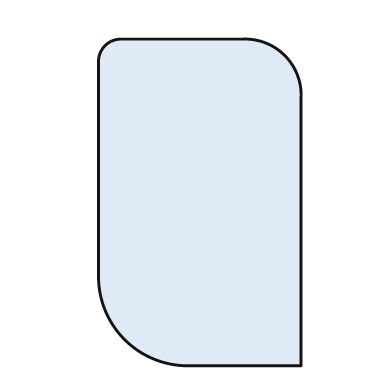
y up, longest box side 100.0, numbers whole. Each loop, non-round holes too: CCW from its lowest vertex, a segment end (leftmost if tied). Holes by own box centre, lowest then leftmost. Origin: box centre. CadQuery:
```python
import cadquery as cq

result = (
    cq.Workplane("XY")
    .moveTo(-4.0, -50.0)
    .lineTo(31.0, -50.0)
    .lineTo(31.0, 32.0)
    .threePointArc((26.0, 45.0), (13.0, 50.0))
    .lineTo(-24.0, 50.0)
    .threePointArc((-29.0, 48.0), (-31.0, 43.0))
    .lineTo(-31.0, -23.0)
    .threePointArc((-23.0, -42.0), (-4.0, -50.0))
    .close()
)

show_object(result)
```